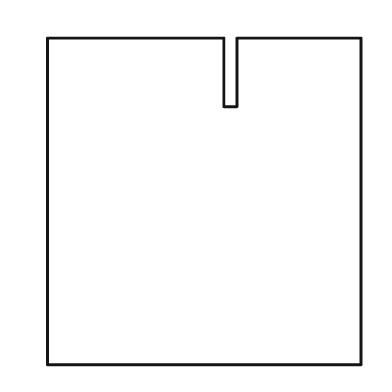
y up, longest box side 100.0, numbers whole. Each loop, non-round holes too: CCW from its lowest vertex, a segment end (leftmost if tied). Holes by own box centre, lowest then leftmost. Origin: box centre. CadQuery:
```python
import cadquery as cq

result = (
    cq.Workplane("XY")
    .moveTo(-48.0, -50.0)
    .lineTo(48.0, -50.0)
    .lineTo(48.0, 50.0)
    .lineTo(10.0, 50.0)
    .lineTo(10.0, 29.0)
    .lineTo(6.0, 29.0)
    .lineTo(6.0, 50.0)
    .lineTo(-48.0, 50.0)
    .close()
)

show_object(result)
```